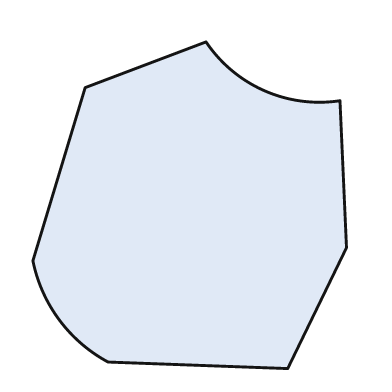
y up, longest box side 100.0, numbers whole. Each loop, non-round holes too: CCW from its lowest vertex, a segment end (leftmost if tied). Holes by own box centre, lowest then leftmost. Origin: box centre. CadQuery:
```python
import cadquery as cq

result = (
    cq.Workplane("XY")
    .moveTo(30.0, -50.0)
    .lineTo(48.0, -13.0)
    .lineTo(46.0, 32.0)
    .threePointArc((23.0, 35.0), (5.0, 50.0))
    .lineTo(-32.0, 36.0)
    .lineTo(-48.0, -17.0)
    .threePointArc((-40.0, -35.0), (-25.0, -48.0))
    .close()
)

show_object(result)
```